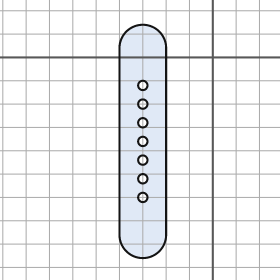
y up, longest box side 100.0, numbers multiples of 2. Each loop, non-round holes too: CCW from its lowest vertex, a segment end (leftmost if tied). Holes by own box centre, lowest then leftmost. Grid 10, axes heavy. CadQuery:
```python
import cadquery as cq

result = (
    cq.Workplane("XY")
    .moveTo(-40.0, -76.0)
    .threePointArc((-30.0, -86.0), (-20.0, -76.0))
    .lineTo(-20.0, 4.0)
    .threePointArc((-30.0, 14.0), (-40.0, 4.0))
    .close()
    .moveTo(-30.0, -60.0)
    .circle(2.0)
    .moveTo(-30.0, -52.0)
    .circle(2.0)
    .moveTo(-30.0, -44.0)
    .circle(2.0)
    .moveTo(-30.0, -36.0)
    .circle(2.0)
    .moveTo(-30.0, -28.0)
    .circle(2.0)
    .moveTo(-30.0, -20.0)
    .circle(2.0)
    .moveTo(-30.0, -12.0)
    .circle(2.0)
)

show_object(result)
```